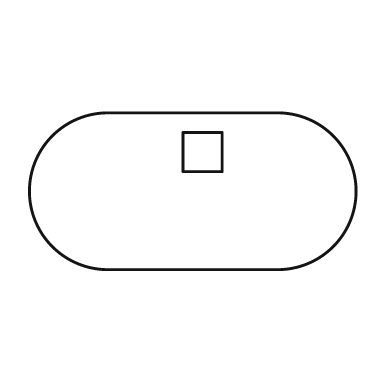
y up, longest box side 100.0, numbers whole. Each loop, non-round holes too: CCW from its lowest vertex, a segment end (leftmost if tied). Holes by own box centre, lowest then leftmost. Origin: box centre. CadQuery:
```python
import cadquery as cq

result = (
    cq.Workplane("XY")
    .moveTo(-26.0, -24.0)
    .lineTo(26.0, -24.0)
    .threePointArc((50.0, 0.0), (26.0, 24.0))
    .lineTo(-26.0, 24.0)
    .threePointArc((-50.0, 0.0), (-26.0, -24.0))
    .close()
    .moveTo(-3.0, 6.0)
    .lineTo(9.0, 6.0)
    .lineTo(9.0, 18.0)
    .lineTo(-3.0, 18.0)
    .close()
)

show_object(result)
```